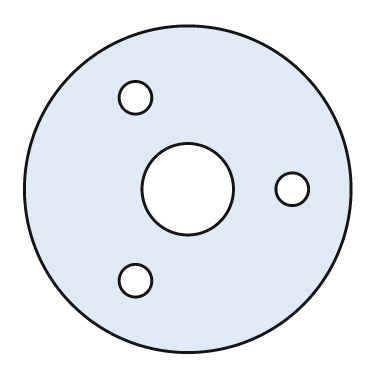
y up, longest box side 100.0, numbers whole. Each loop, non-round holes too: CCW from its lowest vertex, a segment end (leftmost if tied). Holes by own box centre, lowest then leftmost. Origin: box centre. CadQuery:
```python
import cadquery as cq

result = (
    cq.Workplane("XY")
    .moveTo(0.0, 0.0)
    .circle(50.0)
    .moveTo(-16.0, -28.0)
    .circle(5.0)
    .moveTo(0.0, 0.0)
    .circle(14.0)
    .moveTo(32.0, 0.0)
    .circle(5.0)
    .moveTo(-16.0, 28.0)
    .circle(5.0)
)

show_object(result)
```